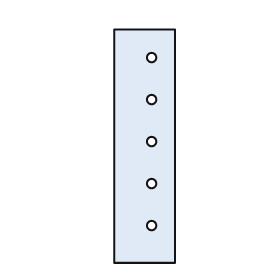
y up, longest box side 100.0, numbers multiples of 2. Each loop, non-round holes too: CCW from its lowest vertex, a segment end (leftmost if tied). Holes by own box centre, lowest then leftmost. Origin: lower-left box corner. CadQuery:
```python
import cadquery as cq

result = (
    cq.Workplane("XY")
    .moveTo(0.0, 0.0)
    .lineTo(26.0, 0.0)
    .lineTo(26.0, 100.0)
    .lineTo(0.0, 100.0)
    .close()
    .moveTo(16.0, 16.0)
    .circle(2.0)
    .moveTo(16.0, 34.0)
    .circle(2.0)
    .moveTo(16.0, 52.0)
    .circle(2.0)
    .moveTo(16.0, 70.0)
    .circle(2.0)
    .moveTo(16.0, 88.0)
    .circle(2.0)
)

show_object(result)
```